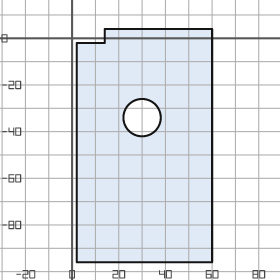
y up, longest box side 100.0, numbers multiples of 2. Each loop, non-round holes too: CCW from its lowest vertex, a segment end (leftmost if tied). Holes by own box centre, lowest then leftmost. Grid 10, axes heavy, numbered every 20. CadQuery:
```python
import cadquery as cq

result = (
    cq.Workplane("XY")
    .moveTo(2.0, -96.0)
    .lineTo(60.0, -96.0)
    .lineTo(60.0, 4.0)
    .lineTo(14.0, 4.0)
    .lineTo(14.0, -2.0)
    .lineTo(2.0, -2.0)
    .close()
    .moveTo(30.0, -34.0)
    .circle(8.0)
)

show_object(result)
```